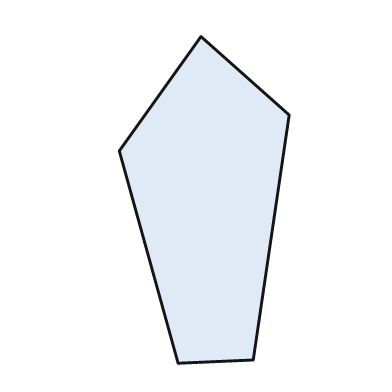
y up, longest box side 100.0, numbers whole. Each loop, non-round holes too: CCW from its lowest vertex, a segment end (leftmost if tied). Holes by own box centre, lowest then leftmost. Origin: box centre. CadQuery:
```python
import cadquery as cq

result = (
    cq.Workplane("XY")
    .moveTo(-8.0, -50.0)
    .lineTo(15.0, -49.0)
    .lineTo(26.0, 26.0)
    .lineTo(-1.0, 50.0)
    .lineTo(-26.0, 15.0)
    .close()
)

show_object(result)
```